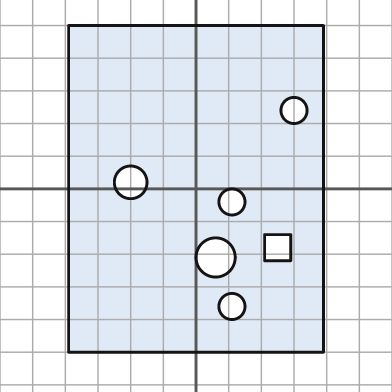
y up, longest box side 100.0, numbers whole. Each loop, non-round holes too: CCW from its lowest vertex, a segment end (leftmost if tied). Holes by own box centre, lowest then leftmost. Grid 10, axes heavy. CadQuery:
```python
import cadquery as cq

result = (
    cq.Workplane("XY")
    .moveTo(-39.0, -50.0)
    .lineTo(39.0, -50.0)
    .lineTo(39.0, 50.0)
    .lineTo(-39.0, 50.0)
    .close()
    .moveTo(11.0, -36.0)
    .circle(4.0)
    .moveTo(6.0, -21.0)
    .circle(6.0)
    .moveTo(21.0, -22.0)
    .lineTo(29.0, -22.0)
    .lineTo(29.0, -14.0)
    .lineTo(21.0, -14.0)
    .close()
    .moveTo(11.0, -4.0)
    .circle(4.0)
    .moveTo(-20.0, 2.0)
    .circle(5.0)
    .moveTo(30.0, 24.0)
    .circle(4.0)
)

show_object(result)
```